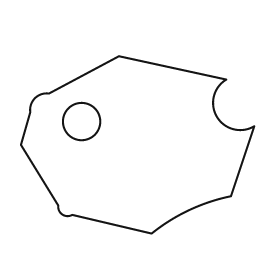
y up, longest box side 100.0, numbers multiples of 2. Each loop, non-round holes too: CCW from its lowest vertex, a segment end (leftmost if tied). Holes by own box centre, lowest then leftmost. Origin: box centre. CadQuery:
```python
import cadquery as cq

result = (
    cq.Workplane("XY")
    .moveTo(6.0, -38.0)
    .threePointArc((22.0, -28.0), (40.0, -22.0))
    .lineTo(50.0, 8.0)
    .threePointArc((34.0, 12.0), (38.0, 28.0))
    .lineTo(-8.0, 38.0)
    .lineTo(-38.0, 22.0)
    .threePointArc((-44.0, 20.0), (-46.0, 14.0))
    .lineTo(-50.0, 0.0)
    .lineTo(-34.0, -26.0)
    .threePointArc((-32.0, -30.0), (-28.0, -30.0))
    .close()
    .moveTo(-24.0, 10.0)
    .circle(8.0)
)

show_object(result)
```